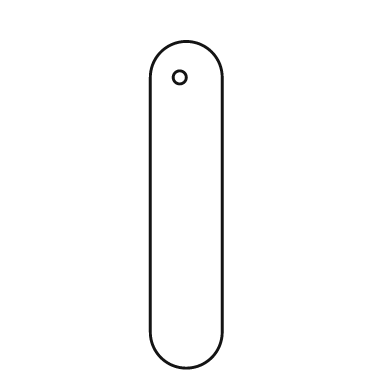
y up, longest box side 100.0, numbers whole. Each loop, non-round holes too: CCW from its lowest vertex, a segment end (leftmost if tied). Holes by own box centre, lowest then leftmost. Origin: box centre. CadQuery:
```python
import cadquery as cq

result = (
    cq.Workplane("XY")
    .moveTo(-11.0, -39.0)
    .threePointArc((0.0, -50.0), (11.0, -39.0))
    .lineTo(11.0, 39.0)
    .threePointArc((0.0, 50.0), (-11.0, 39.0))
    .close()
    .moveTo(-2.0, 39.0)
    .circle(2.0)
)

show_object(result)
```